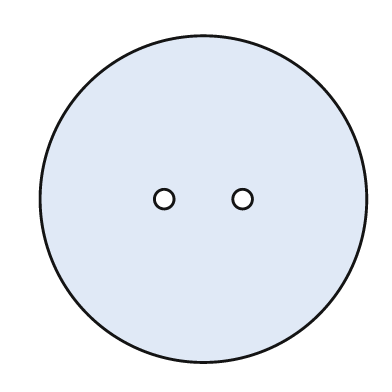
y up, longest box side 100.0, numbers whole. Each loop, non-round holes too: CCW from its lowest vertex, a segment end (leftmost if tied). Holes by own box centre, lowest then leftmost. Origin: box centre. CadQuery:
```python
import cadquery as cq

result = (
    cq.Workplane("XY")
    .moveTo(0.0, 0.0)
    .circle(50.0)
    .moveTo(-12.0, 0.0)
    .circle(3.0)
    .moveTo(12.0, 0.0)
    .circle(3.0)
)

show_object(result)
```